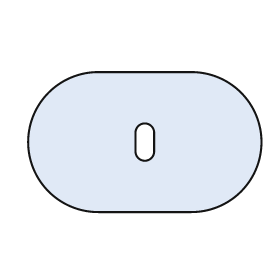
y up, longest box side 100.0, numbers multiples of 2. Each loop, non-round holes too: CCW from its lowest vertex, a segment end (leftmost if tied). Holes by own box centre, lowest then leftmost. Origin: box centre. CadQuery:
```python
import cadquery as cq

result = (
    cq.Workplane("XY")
    .moveTo(-20.0, -30.0)
    .lineTo(20.0, -30.0)
    .threePointArc((50.0, 0.0), (20.0, 30.0))
    .lineTo(-20.0, 30.0)
    .threePointArc((-50.0, 0.0), (-20.0, -30.0))
    .close()
    .moveTo(-4.0, -4.0)
    .threePointArc((0.0, -8.0), (4.0, -4.0))
    .lineTo(4.0, 4.0)
    .threePointArc((0.0, 8.0), (-4.0, 4.0))
    .close()
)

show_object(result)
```